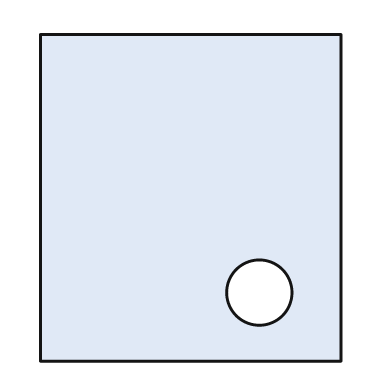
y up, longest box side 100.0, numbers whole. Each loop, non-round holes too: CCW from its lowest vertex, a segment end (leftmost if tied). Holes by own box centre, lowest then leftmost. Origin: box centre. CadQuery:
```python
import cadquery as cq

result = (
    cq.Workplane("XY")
    .moveTo(-46.0, -50.0)
    .lineTo(46.0, -50.0)
    .lineTo(46.0, 50.0)
    .lineTo(-46.0, 50.0)
    .close()
    .moveTo(21.0, -29.0)
    .circle(10.0)
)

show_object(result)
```